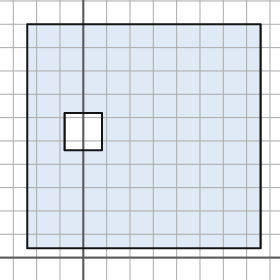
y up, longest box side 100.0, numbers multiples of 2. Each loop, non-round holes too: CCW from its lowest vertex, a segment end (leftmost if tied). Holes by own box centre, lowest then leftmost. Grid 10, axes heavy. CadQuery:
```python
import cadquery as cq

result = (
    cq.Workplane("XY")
    .moveTo(-24.0, 4.0)
    .lineTo(76.0, 4.0)
    .lineTo(76.0, 100.0)
    .lineTo(-24.0, 100.0)
    .close()
    .moveTo(-8.0, 46.0)
    .lineTo(8.0, 46.0)
    .lineTo(8.0, 62.0)
    .lineTo(-8.0, 62.0)
    .close()
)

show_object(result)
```